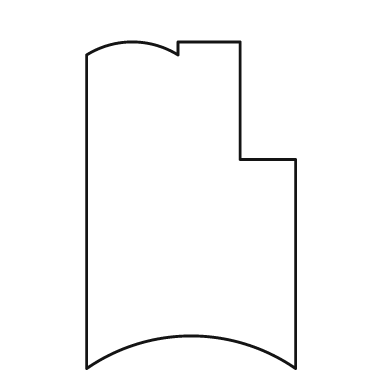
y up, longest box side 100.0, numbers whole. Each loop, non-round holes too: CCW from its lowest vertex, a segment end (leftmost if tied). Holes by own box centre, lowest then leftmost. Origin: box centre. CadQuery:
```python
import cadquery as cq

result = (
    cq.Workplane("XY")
    .moveTo(-32.0, -50.0)
    .threePointArc((0.0, -40.0), (32.0, -50.0))
    .lineTo(32.0, 14.0)
    .lineTo(15.0, 14.0)
    .lineTo(15.0, 50.0)
    .lineTo(-4.0, 50.0)
    .lineTo(-4.0, 46.0)
    .threePointArc((-18.0, 50.0), (-32.0, 46.0))
    .close()
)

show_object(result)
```